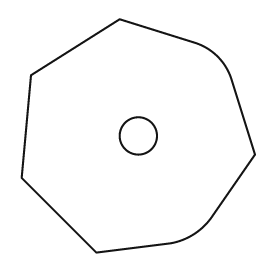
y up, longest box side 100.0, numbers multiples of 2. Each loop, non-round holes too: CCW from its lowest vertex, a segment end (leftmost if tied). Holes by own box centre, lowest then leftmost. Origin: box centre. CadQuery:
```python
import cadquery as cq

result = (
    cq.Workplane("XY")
    .moveTo(-18.0, -50.0)
    .lineTo(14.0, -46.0)
    .threePointArc((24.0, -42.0), (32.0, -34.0))
    .lineTo(50.0, -8.0)
    .lineTo(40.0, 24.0)
    .threePointArc((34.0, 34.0), (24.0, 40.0))
    .lineTo(-8.0, 50.0)
    .lineTo(-46.0, 26.0)
    .lineTo(-50.0, -18.0)
    .close()
    .moveTo(0.0, 0.0)
    .circle(8.0)
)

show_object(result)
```